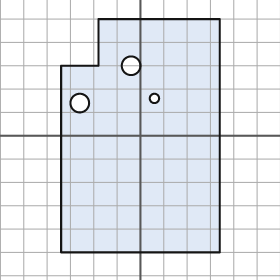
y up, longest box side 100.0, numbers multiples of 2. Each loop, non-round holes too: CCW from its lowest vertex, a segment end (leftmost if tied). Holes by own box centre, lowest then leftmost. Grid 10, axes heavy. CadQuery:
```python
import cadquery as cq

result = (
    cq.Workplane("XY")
    .moveTo(-34.0, -50.0)
    .lineTo(34.0, -50.0)
    .lineTo(34.0, 50.0)
    .lineTo(-18.0, 50.0)
    .lineTo(-18.0, 30.0)
    .lineTo(-34.0, 30.0)
    .close()
    .moveTo(-26.0, 14.0)
    .circle(4.0)
    .moveTo(6.0, 16.0)
    .circle(2.0)
    .moveTo(-4.0, 30.0)
    .circle(4.0)
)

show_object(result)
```